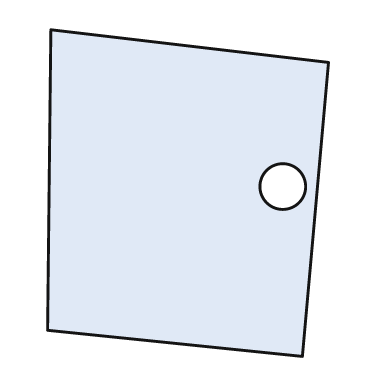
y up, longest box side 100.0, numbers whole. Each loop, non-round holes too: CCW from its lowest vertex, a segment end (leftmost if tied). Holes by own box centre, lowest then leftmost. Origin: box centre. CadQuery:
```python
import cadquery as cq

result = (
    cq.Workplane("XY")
    .moveTo(35.0, -50.0)
    .lineTo(43.0, 40.0)
    .lineTo(-42.0, 50.0)
    .lineTo(-43.0, -42.0)
    .close()
    .moveTo(29.0, 2.0)
    .circle(7.0)
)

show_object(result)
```